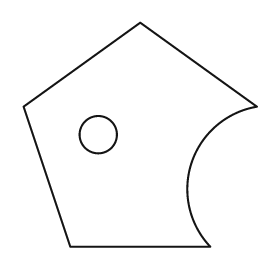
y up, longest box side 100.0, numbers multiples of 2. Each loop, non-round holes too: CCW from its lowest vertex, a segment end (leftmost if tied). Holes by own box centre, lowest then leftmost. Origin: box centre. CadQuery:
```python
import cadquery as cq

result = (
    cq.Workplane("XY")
    .moveTo(-30.0, -48.0)
    .lineTo(30.0, -48.0)
    .threePointArc((22.0, -12.0), (50.0, 12.0))
    .lineTo(0.0, 48.0)
    .lineTo(-50.0, 12.0)
    .close()
    .moveTo(-18.0, 0.0)
    .circle(8.0)
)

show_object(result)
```